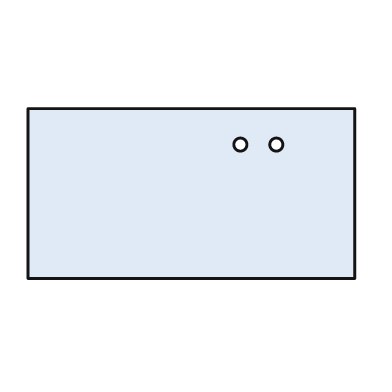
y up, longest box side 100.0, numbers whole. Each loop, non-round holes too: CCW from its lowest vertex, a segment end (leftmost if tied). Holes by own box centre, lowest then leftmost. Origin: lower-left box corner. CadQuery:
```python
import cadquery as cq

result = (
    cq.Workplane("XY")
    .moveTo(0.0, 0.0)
    .lineTo(100.0, 0.0)
    .lineTo(100.0, 52.0)
    .lineTo(0.0, 52.0)
    .close()
    .moveTo(65.0, 41.0)
    .circle(2.0)
    .moveTo(76.0, 41.0)
    .circle(2.0)
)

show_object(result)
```